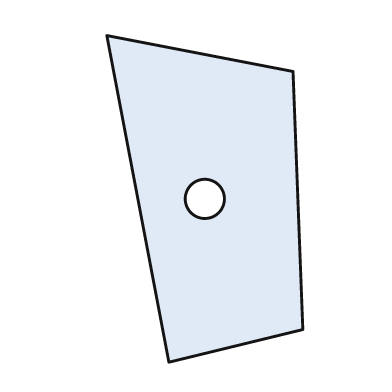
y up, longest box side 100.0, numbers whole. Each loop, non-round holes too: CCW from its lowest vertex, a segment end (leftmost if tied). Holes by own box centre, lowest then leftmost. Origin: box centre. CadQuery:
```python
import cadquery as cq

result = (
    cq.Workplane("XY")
    .moveTo(-11.0, -50.0)
    .lineTo(30.0, -40.0)
    .lineTo(27.0, 39.0)
    .lineTo(-30.0, 50.0)
    .close()
    .moveTo(0.0, 0.0)
    .circle(6.0)
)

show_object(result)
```